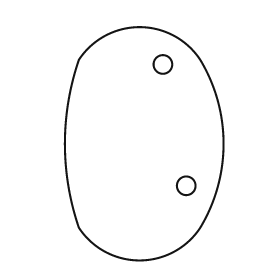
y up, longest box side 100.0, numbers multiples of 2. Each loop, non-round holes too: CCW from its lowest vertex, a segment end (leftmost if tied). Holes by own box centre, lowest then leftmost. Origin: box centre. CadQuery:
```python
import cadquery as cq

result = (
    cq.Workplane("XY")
    .moveTo(-28.0, -36.0)
    .threePointArc((-2.0, -50.0), (24.0, -36.0))
    .threePointArc((34.0, 0.0), (24.0, 36.0))
    .threePointArc((-2.0, 50.0), (-28.0, 36.0))
    .threePointArc((-34.0, 0.0), (-28.0, -36.0))
    .close()
    .moveTo(18.0, -18.0)
    .circle(4.0)
    .moveTo(8.0, 34.0)
    .circle(4.0)
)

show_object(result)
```